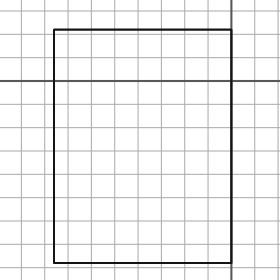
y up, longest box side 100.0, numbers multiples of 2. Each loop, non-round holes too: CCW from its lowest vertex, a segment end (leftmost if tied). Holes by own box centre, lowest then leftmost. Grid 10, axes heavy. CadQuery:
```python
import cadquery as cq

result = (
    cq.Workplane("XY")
    .moveTo(-76.0, -78.0)
    .lineTo(0.0, -78.0)
    .lineTo(0.0, 22.0)
    .lineTo(-76.0, 22.0)
    .close()
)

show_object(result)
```